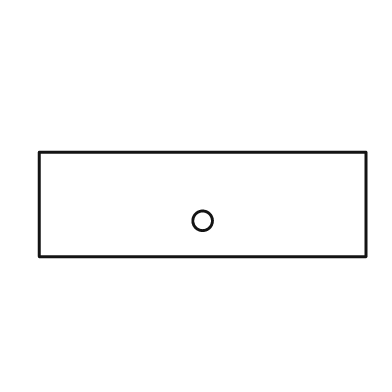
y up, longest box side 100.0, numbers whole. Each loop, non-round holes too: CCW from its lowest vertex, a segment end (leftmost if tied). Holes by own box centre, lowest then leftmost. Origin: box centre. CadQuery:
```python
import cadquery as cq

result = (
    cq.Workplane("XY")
    .moveTo(-50.0, -16.0)
    .lineTo(50.0, -16.0)
    .lineTo(50.0, 16.0)
    .lineTo(-50.0, 16.0)
    .close()
    .moveTo(0.0, -5.0)
    .circle(3.0)
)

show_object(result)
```